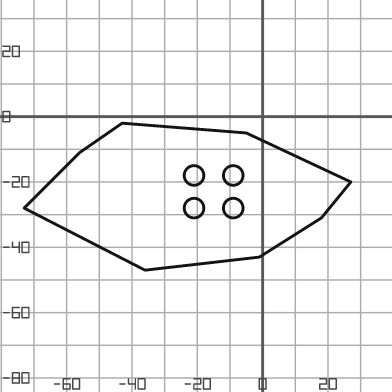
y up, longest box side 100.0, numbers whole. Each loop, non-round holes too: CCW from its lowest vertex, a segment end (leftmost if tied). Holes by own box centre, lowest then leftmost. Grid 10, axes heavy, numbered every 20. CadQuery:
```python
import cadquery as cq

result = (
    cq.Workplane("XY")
    .moveTo(-36.0, -47.0)
    .lineTo(-1.0, -43.0)
    .lineTo(18.0, -31.0)
    .lineTo(27.0, -20.0)
    .lineTo(-5.0, -5.0)
    .lineTo(-43.0, -2.0)
    .lineTo(-56.0, -11.0)
    .lineTo(-73.0, -28.0)
    .close()
    .moveTo(-21.0, -28.0)
    .circle(3.0)
    .moveTo(-9.0, -28.0)
    .circle(3.0)
    .moveTo(-21.0, -18.0)
    .circle(3.0)
    .moveTo(-9.0, -18.0)
    .circle(3.0)
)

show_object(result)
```